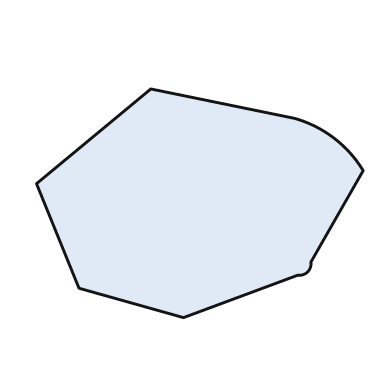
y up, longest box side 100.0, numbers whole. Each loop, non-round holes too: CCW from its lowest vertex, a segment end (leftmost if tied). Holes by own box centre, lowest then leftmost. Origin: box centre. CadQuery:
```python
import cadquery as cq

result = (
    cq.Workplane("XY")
    .moveTo(-5.0, -35.0)
    .lineTo(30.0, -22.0)
    .threePointArc((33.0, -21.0), (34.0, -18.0))
    .lineTo(50.0, 10.0)
    .threePointArc((41.0, 20.0), (29.0, 26.0))
    .lineTo(-15.0, 35.0)
    .lineTo(-50.0, 6.0)
    .lineTo(-37.0, -26.0)
    .close()
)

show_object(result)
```